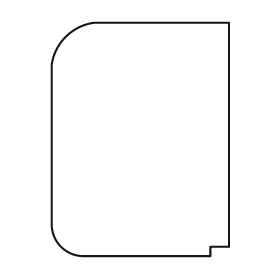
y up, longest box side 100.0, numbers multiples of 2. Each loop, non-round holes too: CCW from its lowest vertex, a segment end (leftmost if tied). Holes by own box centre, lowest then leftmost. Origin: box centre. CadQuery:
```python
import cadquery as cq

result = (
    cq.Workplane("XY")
    .moveTo(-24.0, -50.0)
    .lineTo(30.0, -50.0)
    .lineTo(30.0, -46.0)
    .lineTo(38.0, -46.0)
    .lineTo(38.0, 50.0)
    .lineTo(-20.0, 50.0)
    .threePointArc((-32.0, 44.0), (-38.0, 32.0))
    .lineTo(-38.0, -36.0)
    .threePointArc((-34.0, -46.0), (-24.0, -50.0))
    .close()
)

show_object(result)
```